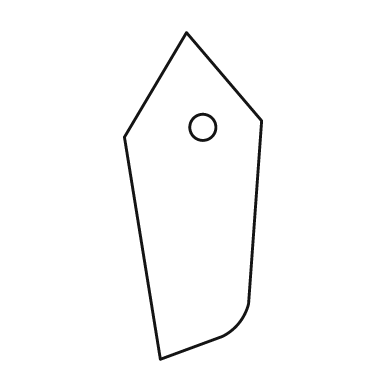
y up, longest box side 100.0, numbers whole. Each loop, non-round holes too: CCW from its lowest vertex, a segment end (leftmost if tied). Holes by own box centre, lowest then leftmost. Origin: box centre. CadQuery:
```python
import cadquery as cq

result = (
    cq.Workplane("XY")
    .moveTo(-10.0, -50.0)
    .lineTo(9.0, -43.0)
    .threePointArc((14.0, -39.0), (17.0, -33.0))
    .lineTo(21.0, 23.0)
    .lineTo(-2.0, 50.0)
    .lineTo(-21.0, 18.0)
    .close()
    .moveTo(3.0, 21.0)
    .circle(4.0)
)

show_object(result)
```